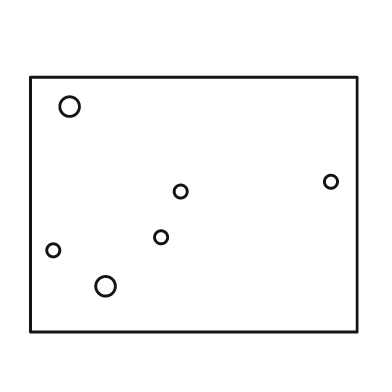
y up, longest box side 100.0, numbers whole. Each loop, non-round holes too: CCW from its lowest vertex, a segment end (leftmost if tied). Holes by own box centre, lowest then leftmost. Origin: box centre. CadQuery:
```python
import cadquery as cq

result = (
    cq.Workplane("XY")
    .moveTo(-50.0, -39.0)
    .lineTo(50.0, -39.0)
    .lineTo(50.0, 39.0)
    .lineTo(-50.0, 39.0)
    .close()
    .moveTo(-27.0, -25.0)
    .circle(3.0)
    .moveTo(-43.0, -14.0)
    .circle(2.0)
    .moveTo(-10.0, -10.0)
    .circle(2.0)
    .moveTo(-4.0, 4.0)
    .circle(2.0)
    .moveTo(42.0, 7.0)
    .circle(2.0)
    .moveTo(-38.0, 30.0)
    .circle(3.0)
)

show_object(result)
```